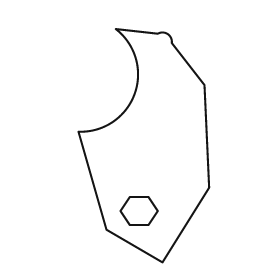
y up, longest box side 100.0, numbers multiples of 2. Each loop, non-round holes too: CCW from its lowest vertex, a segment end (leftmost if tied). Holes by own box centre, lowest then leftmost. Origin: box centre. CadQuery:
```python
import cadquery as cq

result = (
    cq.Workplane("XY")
    .moveTo(8.0, -50.0)
    .lineTo(28.0, -18.0)
    .lineTo(26.0, 26.0)
    .lineTo(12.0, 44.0)
    .threePointArc((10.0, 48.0), (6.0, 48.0))
    .lineTo(-12.0, 50.0)
    .threePointArc((-4.0, 22.0), (-28.0, 6.0))
    .lineTo(-16.0, -36.0)
    .close()
    .moveTo(-6.0, -34.0)
    .lineTo(2.0, -34.0)
    .lineTo(6.0, -28.0)
    .lineTo(2.0, -22.0)
    .lineTo(-6.0, -22.0)
    .lineTo(-10.0, -28.0)
    .close()
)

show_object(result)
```